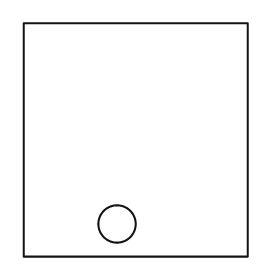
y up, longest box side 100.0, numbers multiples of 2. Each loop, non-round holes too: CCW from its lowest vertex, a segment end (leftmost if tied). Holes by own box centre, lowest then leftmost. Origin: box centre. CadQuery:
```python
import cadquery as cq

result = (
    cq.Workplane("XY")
    .moveTo(-48.0, -50.0)
    .lineTo(48.0, -50.0)
    .lineTo(48.0, 50.0)
    .lineTo(-48.0, 50.0)
    .close()
    .moveTo(-8.0, -36.0)
    .circle(8.0)
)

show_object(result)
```